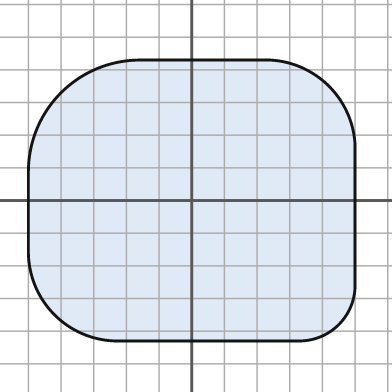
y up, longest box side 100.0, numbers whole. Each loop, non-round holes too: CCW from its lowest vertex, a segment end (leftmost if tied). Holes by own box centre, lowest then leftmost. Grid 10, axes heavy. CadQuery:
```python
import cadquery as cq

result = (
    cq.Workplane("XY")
    .moveTo(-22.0, -43.0)
    .lineTo(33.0, -43.0)
    .threePointArc((45.0, -38.0), (50.0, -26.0))
    .lineTo(50.0, 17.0)
    .threePointArc((42.0, 35.0), (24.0, 43.0))
    .lineTo(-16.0, 43.0)
    .threePointArc((-40.0, 33.0), (-50.0, 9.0))
    .lineTo(-50.0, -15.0)
    .threePointArc((-42.0, -35.0), (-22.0, -43.0))
    .close()
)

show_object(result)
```